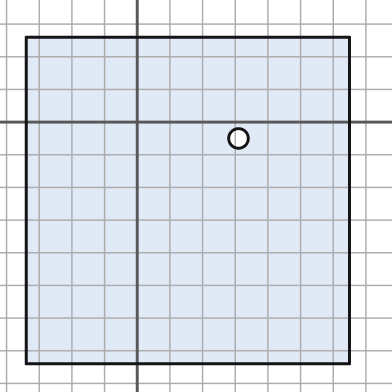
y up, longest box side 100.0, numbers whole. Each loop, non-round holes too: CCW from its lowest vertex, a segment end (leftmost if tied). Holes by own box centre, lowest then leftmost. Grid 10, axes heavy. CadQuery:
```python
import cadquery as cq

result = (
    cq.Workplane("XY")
    .moveTo(-34.0, -74.0)
    .lineTo(65.0, -74.0)
    .lineTo(65.0, 26.0)
    .lineTo(-34.0, 26.0)
    .close()
    .moveTo(31.0, -5.0)
    .circle(3.0)
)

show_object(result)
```